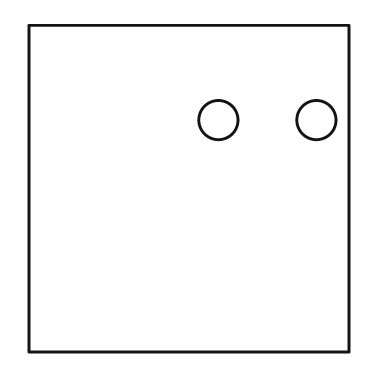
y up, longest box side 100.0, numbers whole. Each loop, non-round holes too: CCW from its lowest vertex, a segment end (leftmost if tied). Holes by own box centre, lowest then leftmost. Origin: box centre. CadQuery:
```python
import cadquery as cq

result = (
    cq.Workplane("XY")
    .moveTo(-49.0, -50.0)
    .lineTo(49.0, -50.0)
    .lineTo(49.0, 50.0)
    .lineTo(-49.0, 50.0)
    .close()
    .moveTo(9.0, 21.0)
    .circle(6.0)
    .moveTo(39.0, 21.0)
    .circle(6.0)
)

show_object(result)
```